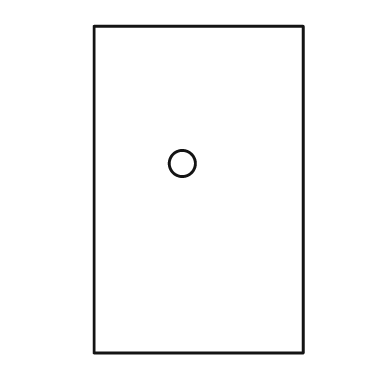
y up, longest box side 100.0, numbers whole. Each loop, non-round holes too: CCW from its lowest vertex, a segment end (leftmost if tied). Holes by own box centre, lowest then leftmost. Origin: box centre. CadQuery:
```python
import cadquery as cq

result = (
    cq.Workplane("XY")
    .moveTo(-32.0, -50.0)
    .lineTo(32.0, -50.0)
    .lineTo(32.0, 50.0)
    .lineTo(-32.0, 50.0)
    .close()
    .moveTo(-5.0, 8.0)
    .circle(4.0)
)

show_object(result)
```